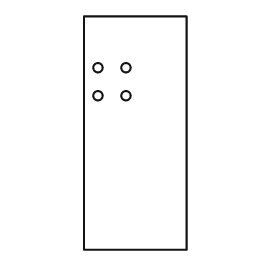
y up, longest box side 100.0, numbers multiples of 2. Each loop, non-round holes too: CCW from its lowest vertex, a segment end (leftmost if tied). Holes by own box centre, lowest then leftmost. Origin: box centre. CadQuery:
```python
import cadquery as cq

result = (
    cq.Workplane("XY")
    .moveTo(-22.0, -50.0)
    .lineTo(22.0, -50.0)
    .lineTo(22.0, 50.0)
    .lineTo(-22.0, 50.0)
    .close()
    .moveTo(-16.0, 16.0)
    .circle(2.0)
    .moveTo(-4.0, 16.0)
    .circle(2.0)
    .moveTo(-16.0, 28.0)
    .circle(2.0)
    .moveTo(-4.0, 28.0)
    .circle(2.0)
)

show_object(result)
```